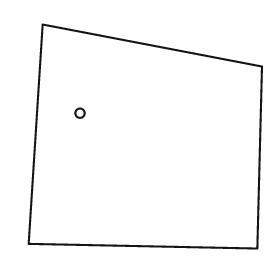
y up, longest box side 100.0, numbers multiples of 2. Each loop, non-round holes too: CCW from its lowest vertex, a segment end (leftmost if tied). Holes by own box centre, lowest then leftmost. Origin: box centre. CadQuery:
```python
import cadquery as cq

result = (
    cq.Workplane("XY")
    .moveTo(48.0, -48.0)
    .lineTo(50.0, 30.0)
    .lineTo(-44.0, 48.0)
    .lineTo(-50.0, -46.0)
    .close()
    .moveTo(-28.0, 10.0)
    .circle(2.0)
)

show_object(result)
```